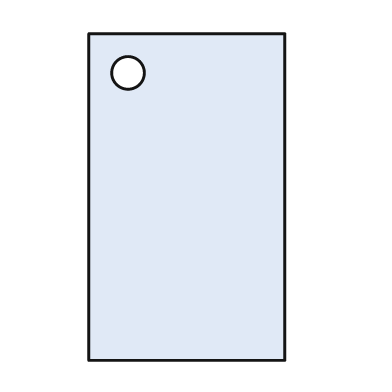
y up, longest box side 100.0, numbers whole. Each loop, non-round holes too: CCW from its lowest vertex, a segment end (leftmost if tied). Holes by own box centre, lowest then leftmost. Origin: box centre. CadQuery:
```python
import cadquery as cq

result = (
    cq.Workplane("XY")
    .moveTo(-30.0, -50.0)
    .lineTo(30.0, -50.0)
    .lineTo(30.0, 50.0)
    .lineTo(-30.0, 50.0)
    .close()
    .moveTo(-18.0, 38.0)
    .circle(5.0)
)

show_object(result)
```